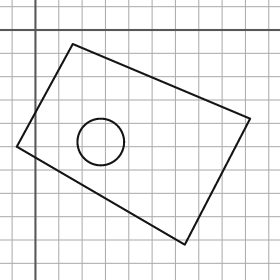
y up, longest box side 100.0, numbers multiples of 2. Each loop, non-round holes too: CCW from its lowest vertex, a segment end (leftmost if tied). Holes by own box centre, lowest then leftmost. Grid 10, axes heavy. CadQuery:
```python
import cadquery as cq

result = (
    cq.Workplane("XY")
    .moveTo(64.0, -92.0)
    .lineTo(92.0, -38.0)
    .lineTo(16.0, -6.0)
    .lineTo(-8.0, -50.0)
    .close()
    .moveTo(28.0, -48.0)
    .circle(10.0)
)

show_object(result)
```